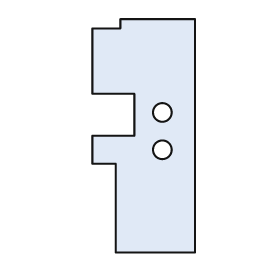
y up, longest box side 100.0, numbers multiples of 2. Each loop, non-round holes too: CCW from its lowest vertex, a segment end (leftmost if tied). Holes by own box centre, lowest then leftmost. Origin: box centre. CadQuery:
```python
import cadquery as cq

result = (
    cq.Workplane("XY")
    .moveTo(-12.0, -50.0)
    .lineTo(22.0, -50.0)
    .lineTo(22.0, 50.0)
    .lineTo(-10.0, 50.0)
    .lineTo(-10.0, 46.0)
    .lineTo(-22.0, 46.0)
    .lineTo(-22.0, 18.0)
    .lineTo(-4.0, 18.0)
    .lineTo(-4.0, 0.0)
    .lineTo(-22.0, 0.0)
    .lineTo(-22.0, -12.0)
    .lineTo(-12.0, -12.0)
    .close()
    .moveTo(8.0, -6.0)
    .circle(4.0)
    .moveTo(8.0, 10.0)
    .circle(4.0)
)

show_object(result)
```